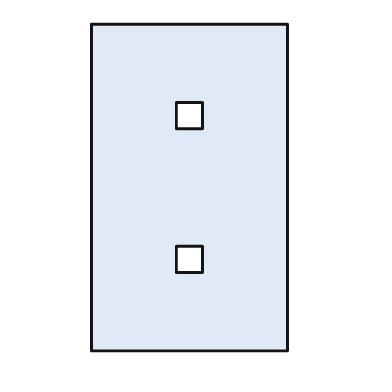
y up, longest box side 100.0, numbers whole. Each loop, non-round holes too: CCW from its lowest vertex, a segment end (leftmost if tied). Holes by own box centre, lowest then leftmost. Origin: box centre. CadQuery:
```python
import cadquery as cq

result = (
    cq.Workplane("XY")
    .moveTo(-30.0, -50.0)
    .lineTo(30.0, -50.0)
    .lineTo(30.0, 50.0)
    .lineTo(-30.0, 50.0)
    .close()
    .moveTo(-4.0, -26.0)
    .lineTo(4.0, -26.0)
    .lineTo(4.0, -18.0)
    .lineTo(-4.0, -18.0)
    .close()
    .moveTo(-4.0, 18.0)
    .lineTo(4.0, 18.0)
    .lineTo(4.0, 26.0)
    .lineTo(-4.0, 26.0)
    .close()
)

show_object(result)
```